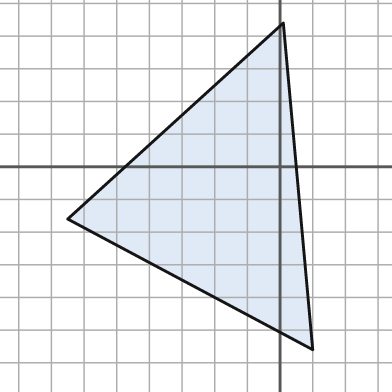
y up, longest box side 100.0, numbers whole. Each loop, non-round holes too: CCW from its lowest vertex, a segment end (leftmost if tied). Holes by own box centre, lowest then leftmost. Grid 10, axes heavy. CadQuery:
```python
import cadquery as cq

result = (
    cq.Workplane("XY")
    .moveTo(10.0, -56.0)
    .lineTo(1.0, 44.0)
    .lineTo(-65.0, -16.0)
    .close()
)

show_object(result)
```